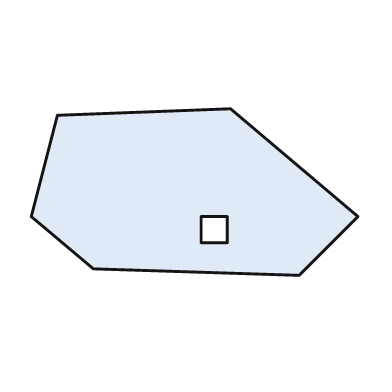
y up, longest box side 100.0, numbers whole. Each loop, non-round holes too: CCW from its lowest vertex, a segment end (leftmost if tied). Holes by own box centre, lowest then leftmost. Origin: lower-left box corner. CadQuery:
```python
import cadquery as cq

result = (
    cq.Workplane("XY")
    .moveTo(82.0, 0.0)
    .lineTo(100.0, 18.0)
    .lineTo(61.0, 51.0)
    .lineTo(8.0, 49.0)
    .lineTo(0.0, 18.0)
    .lineTo(19.0, 2.0)
    .close()
    .moveTo(52.0, 10.0)
    .lineTo(60.0, 10.0)
    .lineTo(60.0, 18.0)
    .lineTo(52.0, 18.0)
    .close()
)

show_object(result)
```